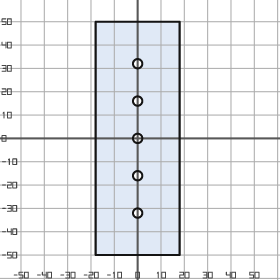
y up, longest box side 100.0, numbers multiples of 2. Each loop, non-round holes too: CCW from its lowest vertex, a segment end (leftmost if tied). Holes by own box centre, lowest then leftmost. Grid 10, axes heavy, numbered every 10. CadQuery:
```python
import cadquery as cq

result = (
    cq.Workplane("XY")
    .moveTo(-18.0, -50.0)
    .lineTo(18.0, -50.0)
    .lineTo(18.0, 50.0)
    .lineTo(-18.0, 50.0)
    .close()
    .moveTo(0.0, -32.0)
    .circle(2.0)
    .moveTo(0.0, -16.0)
    .circle(2.0)
    .moveTo(0.0, 0.0)
    .circle(2.0)
    .moveTo(0.0, 16.0)
    .circle(2.0)
    .moveTo(0.0, 32.0)
    .circle(2.0)
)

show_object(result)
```